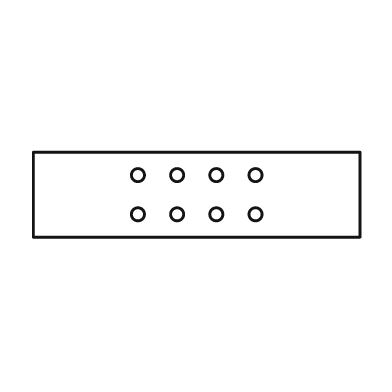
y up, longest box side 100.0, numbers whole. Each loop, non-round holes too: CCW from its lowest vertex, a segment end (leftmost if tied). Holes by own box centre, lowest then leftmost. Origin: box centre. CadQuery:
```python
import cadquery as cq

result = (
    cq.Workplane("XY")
    .moveTo(-50.0, -13.0)
    .lineTo(50.0, -13.0)
    .lineTo(50.0, 13.0)
    .lineTo(-50.0, 13.0)
    .close()
    .moveTo(-18.0, -6.0)
    .circle(2.0)
    .moveTo(-6.0, -6.0)
    .circle(2.0)
    .moveTo(6.0, -6.0)
    .circle(2.0)
    .moveTo(18.0, -6.0)
    .circle(2.0)
    .moveTo(-18.0, 6.0)
    .circle(2.0)
    .moveTo(-6.0, 6.0)
    .circle(2.0)
    .moveTo(6.0, 6.0)
    .circle(2.0)
    .moveTo(18.0, 6.0)
    .circle(2.0)
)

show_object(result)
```